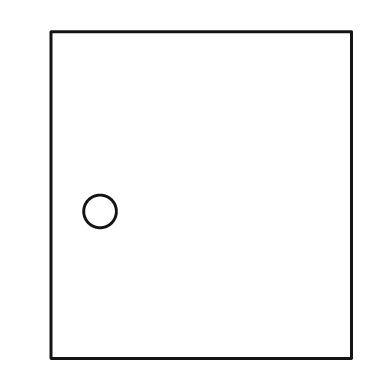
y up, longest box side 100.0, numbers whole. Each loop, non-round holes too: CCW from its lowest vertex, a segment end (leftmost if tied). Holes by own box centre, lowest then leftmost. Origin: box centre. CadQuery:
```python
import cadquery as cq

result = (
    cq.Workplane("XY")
    .moveTo(-46.0, -50.0)
    .lineTo(46.0, -50.0)
    .lineTo(46.0, 50.0)
    .lineTo(-46.0, 50.0)
    .close()
    .moveTo(-31.0, -5.0)
    .circle(5.0)
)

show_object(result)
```